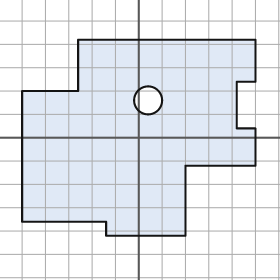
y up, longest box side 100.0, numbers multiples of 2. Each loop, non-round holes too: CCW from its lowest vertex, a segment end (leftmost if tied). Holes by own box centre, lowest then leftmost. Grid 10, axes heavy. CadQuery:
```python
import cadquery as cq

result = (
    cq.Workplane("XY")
    .moveTo(-14.0, -42.0)
    .lineTo(20.0, -42.0)
    .lineTo(20.0, -12.0)
    .lineTo(50.0, -12.0)
    .lineTo(50.0, 4.0)
    .lineTo(42.0, 4.0)
    .lineTo(42.0, 24.0)
    .lineTo(50.0, 24.0)
    .lineTo(50.0, 42.0)
    .lineTo(-26.0, 42.0)
    .lineTo(-26.0, 20.0)
    .lineTo(-50.0, 20.0)
    .lineTo(-50.0, -36.0)
    .lineTo(-14.0, -36.0)
    .close()
    .moveTo(4.0, 16.0)
    .circle(6.0)
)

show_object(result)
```